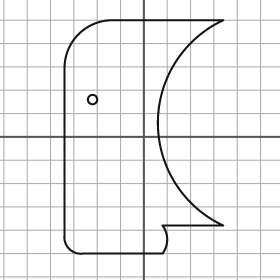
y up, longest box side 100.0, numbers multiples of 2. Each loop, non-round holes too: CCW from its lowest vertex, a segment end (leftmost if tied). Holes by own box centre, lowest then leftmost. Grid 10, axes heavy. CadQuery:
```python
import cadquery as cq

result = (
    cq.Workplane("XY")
    .moveTo(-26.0, -50.0)
    .lineTo(8.0, -50.0)
    .threePointArc((10.0, -44.0), (8.0, -38.0))
    .lineTo(34.0, -38.0)
    .threePointArc((6.0, 6.0), (34.0, 50.0))
    .lineTo(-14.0, 50.0)
    .threePointArc((-28.0, 44.0), (-34.0, 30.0))
    .lineTo(-34.0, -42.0)
    .threePointArc((-32.0, -48.0), (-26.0, -50.0))
    .close()
    .moveTo(-22.0, 16.0)
    .circle(2.0)
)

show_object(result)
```